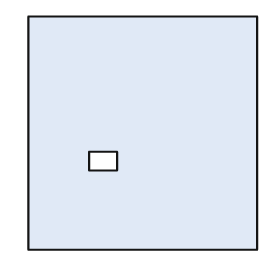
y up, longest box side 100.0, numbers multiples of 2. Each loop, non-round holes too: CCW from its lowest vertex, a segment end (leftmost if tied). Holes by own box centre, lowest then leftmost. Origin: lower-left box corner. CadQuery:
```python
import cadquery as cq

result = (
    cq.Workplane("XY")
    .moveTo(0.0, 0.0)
    .lineTo(98.0, 0.0)
    .lineTo(98.0, 100.0)
    .lineTo(0.0, 100.0)
    .close()
    .moveTo(26.0, 34.0)
    .lineTo(38.0, 34.0)
    .lineTo(38.0, 42.0)
    .lineTo(26.0, 42.0)
    .close()
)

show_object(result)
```